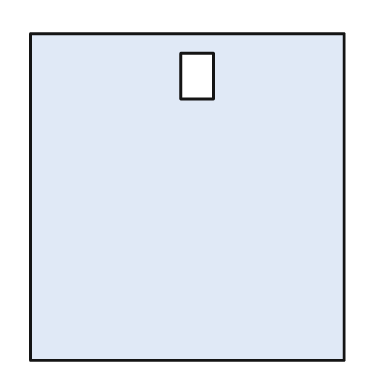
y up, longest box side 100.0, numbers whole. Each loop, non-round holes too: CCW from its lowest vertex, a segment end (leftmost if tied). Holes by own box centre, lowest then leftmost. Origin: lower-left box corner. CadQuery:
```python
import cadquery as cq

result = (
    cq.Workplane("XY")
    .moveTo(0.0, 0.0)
    .lineTo(96.0, 0.0)
    .lineTo(96.0, 100.0)
    .lineTo(0.0, 100.0)
    .close()
    .moveTo(46.0, 80.0)
    .lineTo(56.0, 80.0)
    .lineTo(56.0, 94.0)
    .lineTo(46.0, 94.0)
    .close()
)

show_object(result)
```